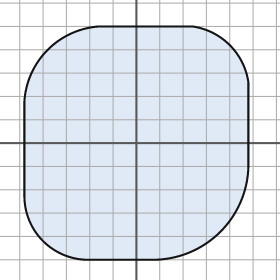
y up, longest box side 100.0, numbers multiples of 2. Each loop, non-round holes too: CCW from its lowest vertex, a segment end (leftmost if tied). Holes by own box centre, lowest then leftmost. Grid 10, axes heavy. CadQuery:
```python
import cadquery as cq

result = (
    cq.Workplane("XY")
    .moveTo(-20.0, -50.0)
    .lineTo(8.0, -50.0)
    .threePointArc((36.0, -38.0), (48.0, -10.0))
    .lineTo(48.0, 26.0)
    .threePointArc((40.0, 42.0), (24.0, 50.0))
    .lineTo(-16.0, 50.0)
    .threePointArc((-38.0, 40.0), (-48.0, 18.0))
    .lineTo(-48.0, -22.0)
    .threePointArc((-40.0, -42.0), (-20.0, -50.0))
    .close()
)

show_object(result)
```